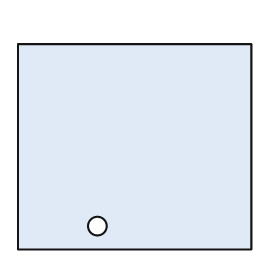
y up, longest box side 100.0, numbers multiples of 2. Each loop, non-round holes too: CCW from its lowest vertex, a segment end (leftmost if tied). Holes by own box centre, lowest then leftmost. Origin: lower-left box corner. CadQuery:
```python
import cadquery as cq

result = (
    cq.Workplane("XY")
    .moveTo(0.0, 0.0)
    .lineTo(100.0, 0.0)
    .lineTo(100.0, 88.0)
    .lineTo(0.0, 88.0)
    .close()
    .moveTo(34.0, 10.0)
    .circle(4.0)
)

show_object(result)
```